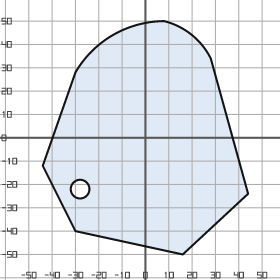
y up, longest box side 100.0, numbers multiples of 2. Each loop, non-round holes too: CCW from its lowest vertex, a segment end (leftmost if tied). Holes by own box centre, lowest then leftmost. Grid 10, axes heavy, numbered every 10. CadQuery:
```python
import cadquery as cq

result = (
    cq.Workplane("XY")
    .moveTo(16.0, -50.0)
    .lineTo(44.0, -24.0)
    .lineTo(28.0, 34.0)
    .threePointArc((20.0, 44.0), (8.0, 50.0))
    .threePointArc((-14.0, 44.0), (-30.0, 28.0))
    .lineTo(-44.0, -12.0)
    .lineTo(-30.0, -40.0)
    .close()
    .moveTo(-28.0, -22.0)
    .circle(4.0)
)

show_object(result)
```